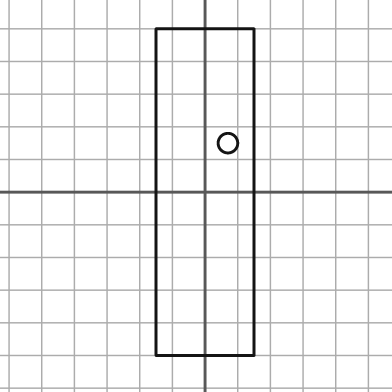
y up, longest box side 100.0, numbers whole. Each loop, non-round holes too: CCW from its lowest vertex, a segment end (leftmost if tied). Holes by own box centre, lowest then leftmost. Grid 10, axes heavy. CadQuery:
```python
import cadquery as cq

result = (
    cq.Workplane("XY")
    .moveTo(-15.0, -50.0)
    .lineTo(15.0, -50.0)
    .lineTo(15.0, 50.0)
    .lineTo(-15.0, 50.0)
    .close()
    .moveTo(7.0, 15.0)
    .circle(3.0)
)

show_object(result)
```